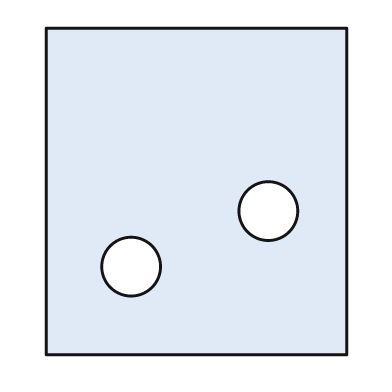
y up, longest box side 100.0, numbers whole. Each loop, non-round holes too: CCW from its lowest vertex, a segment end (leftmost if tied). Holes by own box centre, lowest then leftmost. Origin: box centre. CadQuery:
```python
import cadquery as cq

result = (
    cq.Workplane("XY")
    .moveTo(-46.0, -50.0)
    .lineTo(46.0, -50.0)
    .lineTo(46.0, 50.0)
    .lineTo(-46.0, 50.0)
    .close()
    .moveTo(-20.0, -23.0)
    .circle(9.0)
    .moveTo(22.0, -6.0)
    .circle(9.0)
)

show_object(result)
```